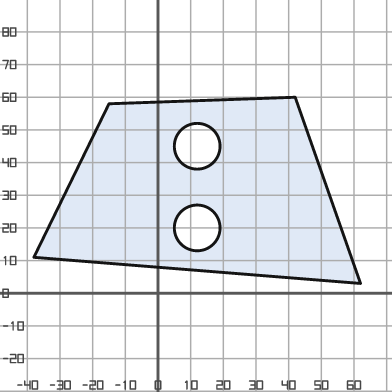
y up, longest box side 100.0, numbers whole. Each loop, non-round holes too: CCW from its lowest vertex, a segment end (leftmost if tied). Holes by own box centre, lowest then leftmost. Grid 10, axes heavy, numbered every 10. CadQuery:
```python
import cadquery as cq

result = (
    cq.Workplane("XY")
    .moveTo(62.0, 3.0)
    .lineTo(42.0, 60.0)
    .lineTo(-15.0, 58.0)
    .lineTo(-38.0, 11.0)
    .close()
    .moveTo(12.0, 20.0)
    .circle(7.0)
    .moveTo(12.0, 45.0)
    .circle(7.0)
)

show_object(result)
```